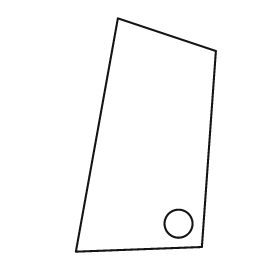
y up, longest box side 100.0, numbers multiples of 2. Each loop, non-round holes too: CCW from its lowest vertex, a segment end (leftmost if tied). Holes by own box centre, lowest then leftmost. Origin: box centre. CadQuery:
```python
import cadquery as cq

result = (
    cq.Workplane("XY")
    .moveTo(-30.0, -50.0)
    .lineTo(24.0, -48.0)
    .lineTo(30.0, 36.0)
    .lineTo(-12.0, 50.0)
    .close()
    .moveTo(14.0, -38.0)
    .circle(6.0)
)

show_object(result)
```